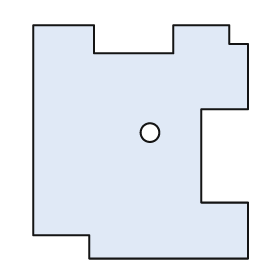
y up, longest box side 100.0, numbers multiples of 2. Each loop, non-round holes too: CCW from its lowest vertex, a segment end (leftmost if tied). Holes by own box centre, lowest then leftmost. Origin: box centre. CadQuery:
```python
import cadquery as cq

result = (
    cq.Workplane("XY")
    .moveTo(-22.0, -50.0)
    .lineTo(46.0, -50.0)
    .lineTo(46.0, -26.0)
    .lineTo(26.0, -26.0)
    .lineTo(26.0, 14.0)
    .lineTo(46.0, 14.0)
    .lineTo(46.0, 42.0)
    .lineTo(38.0, 42.0)
    .lineTo(38.0, 50.0)
    .lineTo(14.0, 50.0)
    .lineTo(14.0, 38.0)
    .lineTo(-20.0, 38.0)
    .lineTo(-20.0, 50.0)
    .lineTo(-46.0, 50.0)
    .lineTo(-46.0, -40.0)
    .lineTo(-22.0, -40.0)
    .close()
    .moveTo(4.0, 4.0)
    .circle(4.0)
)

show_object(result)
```